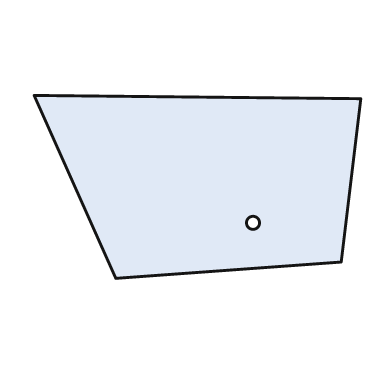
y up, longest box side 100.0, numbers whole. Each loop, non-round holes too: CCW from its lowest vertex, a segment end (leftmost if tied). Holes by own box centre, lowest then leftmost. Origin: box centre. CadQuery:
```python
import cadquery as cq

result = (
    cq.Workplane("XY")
    .moveTo(-25.0, -28.0)
    .lineTo(44.0, -23.0)
    .lineTo(50.0, 27.0)
    .lineTo(-50.0, 28.0)
    .close()
    .moveTo(17.0, -11.0)
    .circle(2.0)
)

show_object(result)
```